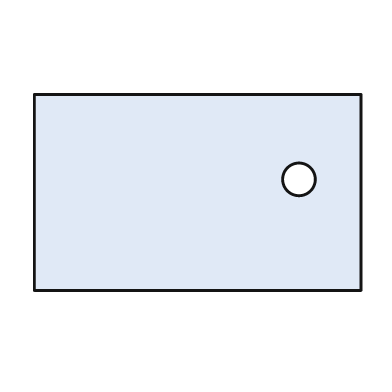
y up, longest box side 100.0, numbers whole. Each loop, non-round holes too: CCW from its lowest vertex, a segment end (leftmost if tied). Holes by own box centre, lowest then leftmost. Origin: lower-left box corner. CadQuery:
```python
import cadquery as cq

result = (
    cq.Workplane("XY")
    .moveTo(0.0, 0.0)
    .lineTo(100.0, 0.0)
    .lineTo(100.0, 60.0)
    .lineTo(0.0, 60.0)
    .close()
    .moveTo(81.0, 34.0)
    .circle(5.0)
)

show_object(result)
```